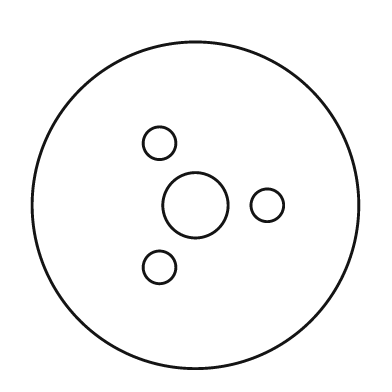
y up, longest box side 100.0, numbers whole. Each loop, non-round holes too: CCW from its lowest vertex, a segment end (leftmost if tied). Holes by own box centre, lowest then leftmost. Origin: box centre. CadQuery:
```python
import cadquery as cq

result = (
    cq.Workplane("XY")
    .moveTo(0.0, 0.0)
    .circle(50.0)
    .moveTo(-11.0, -19.0)
    .circle(5.0)
    .moveTo(0.0, 0.0)
    .circle(10.0)
    .moveTo(22.0, 0.0)
    .circle(5.0)
    .moveTo(-11.0, 19.0)
    .circle(5.0)
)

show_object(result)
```